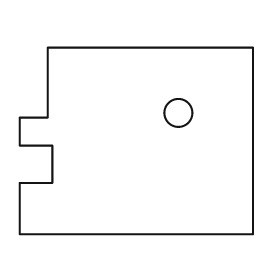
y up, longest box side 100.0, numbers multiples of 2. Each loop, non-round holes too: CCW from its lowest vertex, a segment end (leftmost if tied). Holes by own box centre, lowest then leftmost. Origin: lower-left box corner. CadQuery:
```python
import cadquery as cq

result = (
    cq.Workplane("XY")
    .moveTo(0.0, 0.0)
    .lineTo(100.0, 0.0)
    .lineTo(100.0, 80.0)
    .lineTo(12.0, 80.0)
    .lineTo(12.0, 50.0)
    .lineTo(0.0, 50.0)
    .lineTo(0.0, 38.0)
    .lineTo(14.0, 38.0)
    .lineTo(14.0, 22.0)
    .lineTo(0.0, 22.0)
    .close()
    .moveTo(68.0, 52.0)
    .circle(6.0)
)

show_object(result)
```